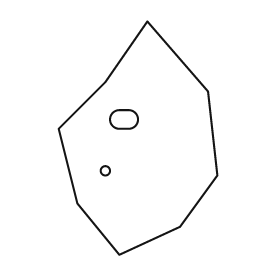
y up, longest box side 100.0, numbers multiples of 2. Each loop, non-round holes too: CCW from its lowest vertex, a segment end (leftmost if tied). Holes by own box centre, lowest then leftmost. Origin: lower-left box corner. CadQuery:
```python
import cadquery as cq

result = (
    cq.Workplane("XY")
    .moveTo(26.0, 0.0)
    .lineTo(52.0, 12.0)
    .lineTo(68.0, 34.0)
    .lineTo(64.0, 70.0)
    .lineTo(38.0, 100.0)
    .lineTo(20.0, 74.0)
    .lineTo(0.0, 54.0)
    .lineTo(8.0, 22.0)
    .close()
    .moveTo(20.0, 36.0)
    .circle(2.0)
    .moveTo(26.0, 54.0)
    .lineTo(30.0, 54.0)
    .threePointArc((34.0, 58.0), (30.0, 62.0))
    .lineTo(26.0, 62.0)
    .threePointArc((22.0, 58.0), (26.0, 54.0))
    .close()
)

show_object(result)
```